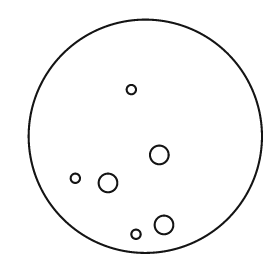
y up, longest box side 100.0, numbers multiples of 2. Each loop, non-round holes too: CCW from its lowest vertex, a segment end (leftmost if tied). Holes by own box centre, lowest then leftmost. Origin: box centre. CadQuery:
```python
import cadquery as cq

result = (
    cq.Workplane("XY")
    .moveTo(0.0, 0.0)
    .circle(50.0)
    .moveTo(-4.0, -42.0)
    .circle(2.0)
    .moveTo(8.0, -38.0)
    .circle(4.0)
    .moveTo(-16.0, -20.0)
    .circle(4.0)
    .moveTo(-30.0, -18.0)
    .circle(2.0)
    .moveTo(6.0, -8.0)
    .circle(4.0)
    .moveTo(-6.0, 20.0)
    .circle(2.0)
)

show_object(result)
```